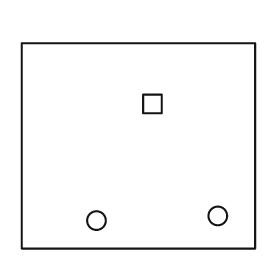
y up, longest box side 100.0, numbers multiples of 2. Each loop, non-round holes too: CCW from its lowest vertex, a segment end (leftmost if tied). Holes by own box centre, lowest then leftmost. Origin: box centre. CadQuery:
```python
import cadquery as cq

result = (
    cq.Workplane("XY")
    .moveTo(-50.0, -44.0)
    .lineTo(50.0, -44.0)
    .lineTo(50.0, 44.0)
    .lineTo(-50.0, 44.0)
    .close()
    .moveTo(-18.0, -32.0)
    .circle(4.0)
    .moveTo(34.0, -30.0)
    .circle(4.0)
    .moveTo(2.0, 14.0)
    .lineTo(10.0, 14.0)
    .lineTo(10.0, 22.0)
    .lineTo(2.0, 22.0)
    .close()
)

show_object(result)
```